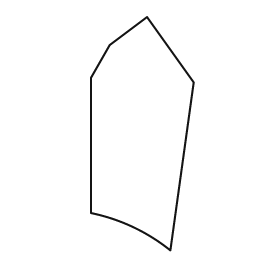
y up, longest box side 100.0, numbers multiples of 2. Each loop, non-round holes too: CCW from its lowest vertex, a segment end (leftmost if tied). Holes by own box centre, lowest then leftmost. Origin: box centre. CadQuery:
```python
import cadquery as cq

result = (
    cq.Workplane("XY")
    .moveTo(12.0, -50.0)
    .lineTo(22.0, 22.0)
    .lineTo(2.0, 50.0)
    .lineTo(-14.0, 38.0)
    .lineTo(-22.0, 24.0)
    .lineTo(-22.0, -34.0)
    .threePointArc((-4.0, -40.0), (12.0, -50.0))
    .close()
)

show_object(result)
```